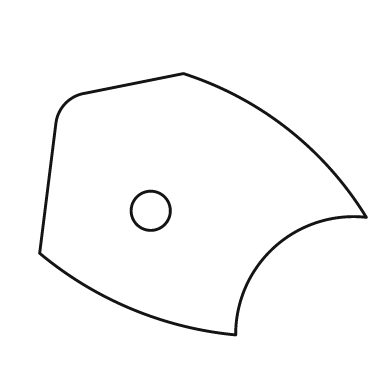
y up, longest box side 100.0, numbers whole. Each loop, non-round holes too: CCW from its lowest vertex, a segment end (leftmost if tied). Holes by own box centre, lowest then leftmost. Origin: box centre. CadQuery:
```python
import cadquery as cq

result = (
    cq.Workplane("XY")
    .moveTo(10.0, -40.0)
    .threePointArc((22.0, -13.0), (50.0, -4.0))
    .threePointArc((26.0, 23.0), (-6.0, 40.0))
    .lineTo(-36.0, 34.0)
    .threePointArc((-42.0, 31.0), (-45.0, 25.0))
    .lineTo(-50.0, -15.0)
    .threePointArc((-22.0, -32.0), (10.0, -40.0))
    .close()
    .moveTo(-16.0, -2.0)
    .circle(6.0)
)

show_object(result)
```